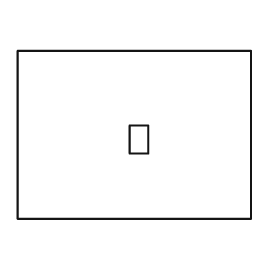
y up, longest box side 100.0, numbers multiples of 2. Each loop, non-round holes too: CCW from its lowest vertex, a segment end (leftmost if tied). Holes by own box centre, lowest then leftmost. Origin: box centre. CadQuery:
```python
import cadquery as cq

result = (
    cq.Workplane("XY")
    .moveTo(-50.0, -36.0)
    .lineTo(50.0, -36.0)
    .lineTo(50.0, 36.0)
    .lineTo(-50.0, 36.0)
    .close()
    .moveTo(-2.0, -8.0)
    .lineTo(6.0, -8.0)
    .lineTo(6.0, 4.0)
    .lineTo(-2.0, 4.0)
    .close()
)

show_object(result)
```